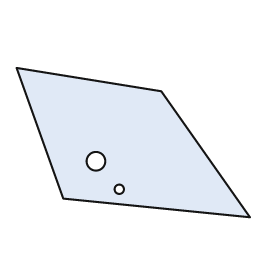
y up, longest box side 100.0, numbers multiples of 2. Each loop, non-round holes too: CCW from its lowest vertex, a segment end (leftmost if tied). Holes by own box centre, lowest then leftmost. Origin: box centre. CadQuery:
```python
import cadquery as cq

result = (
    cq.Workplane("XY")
    .moveTo(50.0, -32.0)
    .lineTo(12.0, 22.0)
    .lineTo(-50.0, 32.0)
    .lineTo(-30.0, -24.0)
    .close()
    .moveTo(-6.0, -20.0)
    .circle(2.0)
    .moveTo(-16.0, -8.0)
    .circle(4.0)
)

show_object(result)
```